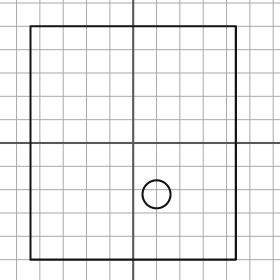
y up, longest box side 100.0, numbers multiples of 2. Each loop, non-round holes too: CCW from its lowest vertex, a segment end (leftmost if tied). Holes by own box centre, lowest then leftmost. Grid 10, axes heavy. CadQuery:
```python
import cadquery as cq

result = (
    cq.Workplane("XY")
    .moveTo(-44.0, -50.0)
    .lineTo(44.0, -50.0)
    .lineTo(44.0, 50.0)
    .lineTo(-44.0, 50.0)
    .close()
    .moveTo(10.0, -22.0)
    .circle(6.0)
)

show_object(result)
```